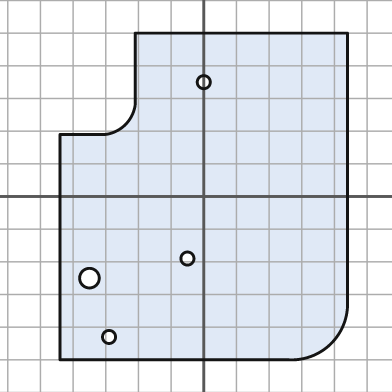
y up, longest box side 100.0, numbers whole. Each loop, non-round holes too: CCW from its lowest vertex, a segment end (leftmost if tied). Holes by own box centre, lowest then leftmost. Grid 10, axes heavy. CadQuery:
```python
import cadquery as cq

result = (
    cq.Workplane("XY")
    .moveTo(-44.0, -50.0)
    .lineTo(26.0, -50.0)
    .threePointArc((39.0, -45.0), (44.0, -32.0))
    .lineTo(44.0, 50.0)
    .lineTo(-21.0, 50.0)
    .lineTo(-21.0, 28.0)
    .threePointArc((-24.0, 22.0), (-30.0, 19.0))
    .lineTo(-44.0, 19.0)
    .close()
    .moveTo(-29.0, -43.0)
    .circle(2.0)
    .moveTo(-35.0, -25.0)
    .circle(3.0)
    .moveTo(-5.0, -19.0)
    .circle(2.0)
    .moveTo(0.0, 35.0)
    .circle(2.0)
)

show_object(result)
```